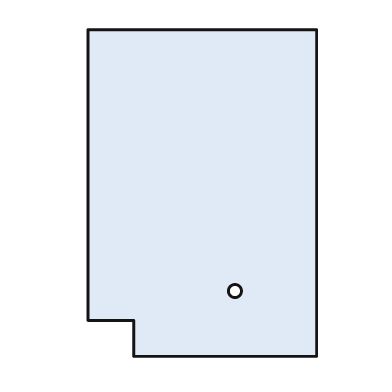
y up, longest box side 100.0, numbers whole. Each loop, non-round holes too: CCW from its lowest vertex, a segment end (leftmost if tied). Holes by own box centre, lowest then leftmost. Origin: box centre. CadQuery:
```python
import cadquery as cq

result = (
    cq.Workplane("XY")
    .moveTo(-21.0, -50.0)
    .lineTo(35.0, -50.0)
    .lineTo(35.0, 50.0)
    .lineTo(-35.0, 50.0)
    .lineTo(-35.0, -39.0)
    .lineTo(-21.0, -39.0)
    .close()
    .moveTo(10.0, -30.0)
    .circle(2.0)
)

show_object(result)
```